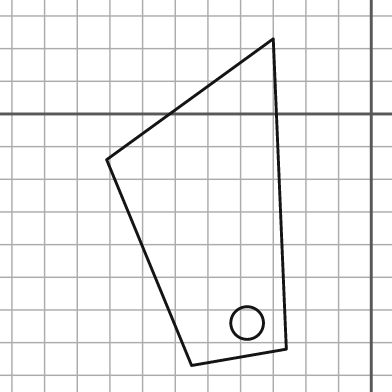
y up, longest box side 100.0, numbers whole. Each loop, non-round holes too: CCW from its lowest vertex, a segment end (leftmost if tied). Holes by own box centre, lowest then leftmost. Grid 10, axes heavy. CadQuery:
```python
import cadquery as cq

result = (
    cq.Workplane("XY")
    .moveTo(-55.0, -77.0)
    .lineTo(-26.0, -72.0)
    .lineTo(-30.0, 23.0)
    .lineTo(-81.0, -14.0)
    .close()
    .moveTo(-38.0, -64.0)
    .circle(5.0)
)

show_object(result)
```